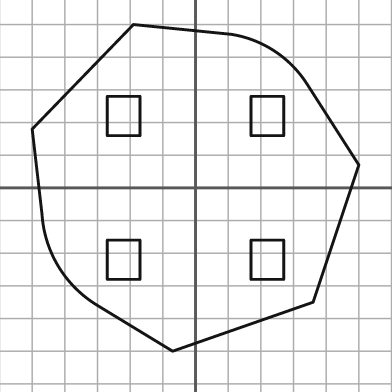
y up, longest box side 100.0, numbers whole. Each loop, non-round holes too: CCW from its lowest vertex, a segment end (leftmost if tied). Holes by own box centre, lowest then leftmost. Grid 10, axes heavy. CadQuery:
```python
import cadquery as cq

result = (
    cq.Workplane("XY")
    .moveTo(-7.0, -50.0)
    .lineTo(36.0, -35.0)
    .lineTo(50.0, 7.0)
    .lineTo(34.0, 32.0)
    .threePointArc((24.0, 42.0), (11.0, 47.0))
    .lineTo(-19.0, 50.0)
    .lineTo(-50.0, 18.0)
    .lineTo(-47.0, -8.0)
    .threePointArc((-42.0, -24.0), (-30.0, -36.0))
    .close()
    .moveTo(-27.0, -28.0)
    .lineTo(-17.0, -28.0)
    .lineTo(-17.0, -16.0)
    .lineTo(-27.0, -16.0)
    .close()
    .moveTo(17.0, -28.0)
    .lineTo(27.0, -28.0)
    .lineTo(27.0, -16.0)
    .lineTo(17.0, -16.0)
    .close()
    .moveTo(-27.0, 16.0)
    .lineTo(-17.0, 16.0)
    .lineTo(-17.0, 28.0)
    .lineTo(-27.0, 28.0)
    .close()
    .moveTo(17.0, 16.0)
    .lineTo(27.0, 16.0)
    .lineTo(27.0, 28.0)
    .lineTo(17.0, 28.0)
    .close()
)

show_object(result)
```